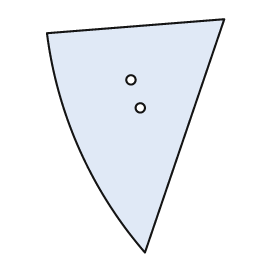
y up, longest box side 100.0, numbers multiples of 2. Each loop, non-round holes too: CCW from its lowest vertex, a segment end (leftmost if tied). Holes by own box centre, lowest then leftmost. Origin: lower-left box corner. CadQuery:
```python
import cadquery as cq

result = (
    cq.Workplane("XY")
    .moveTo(42.0, 0.0)
    .lineTo(76.0, 100.0)
    .lineTo(0.0, 94.0)
    .threePointArc((14.0, 44.0), (42.0, 0.0))
    .close()
    .moveTo(40.0, 62.0)
    .circle(2.0)
    .moveTo(36.0, 74.0)
    .circle(2.0)
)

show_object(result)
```